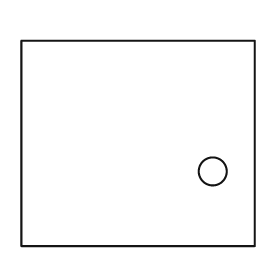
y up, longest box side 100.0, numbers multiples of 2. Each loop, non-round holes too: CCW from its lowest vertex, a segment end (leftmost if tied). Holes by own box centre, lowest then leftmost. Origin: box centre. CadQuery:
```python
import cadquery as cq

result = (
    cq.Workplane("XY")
    .moveTo(-50.0, -44.0)
    .lineTo(50.0, -44.0)
    .lineTo(50.0, 44.0)
    .lineTo(-50.0, 44.0)
    .close()
    .moveTo(32.0, -12.0)
    .circle(6.0)
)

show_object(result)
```